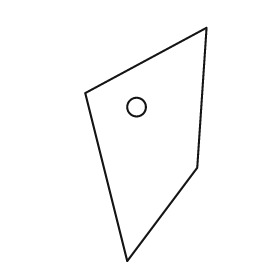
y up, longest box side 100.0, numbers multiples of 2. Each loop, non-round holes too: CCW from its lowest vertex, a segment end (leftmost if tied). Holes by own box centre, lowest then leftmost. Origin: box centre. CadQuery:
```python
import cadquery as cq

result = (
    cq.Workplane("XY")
    .moveTo(-8.0, -50.0)
    .lineTo(22.0, -10.0)
    .lineTo(26.0, 50.0)
    .lineTo(-26.0, 22.0)
    .close()
    .moveTo(-4.0, 16.0)
    .circle(4.0)
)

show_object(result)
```